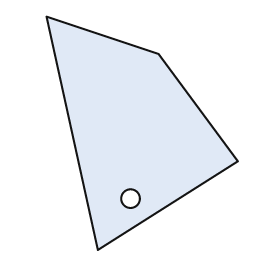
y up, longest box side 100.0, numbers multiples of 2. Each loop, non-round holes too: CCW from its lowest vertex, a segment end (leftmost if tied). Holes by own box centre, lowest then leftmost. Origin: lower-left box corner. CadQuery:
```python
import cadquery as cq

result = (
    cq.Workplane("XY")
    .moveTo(22.0, 0.0)
    .lineTo(82.0, 38.0)
    .lineTo(48.0, 84.0)
    .lineTo(0.0, 100.0)
    .close()
    .moveTo(36.0, 22.0)
    .circle(4.0)
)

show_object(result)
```